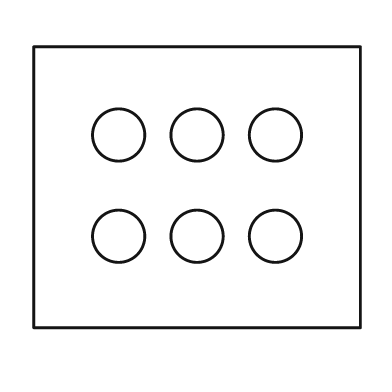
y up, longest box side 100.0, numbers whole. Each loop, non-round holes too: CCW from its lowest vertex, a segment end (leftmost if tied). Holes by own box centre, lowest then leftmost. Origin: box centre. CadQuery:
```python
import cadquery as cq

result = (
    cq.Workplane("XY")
    .moveTo(-50.0, -43.0)
    .lineTo(50.0, -43.0)
    .lineTo(50.0, 43.0)
    .lineTo(-50.0, 43.0)
    .close()
    .moveTo(-24.0, -15.0)
    .circle(8.0)
    .moveTo(0.0, -15.0)
    .circle(8.0)
    .moveTo(24.0, -15.0)
    .circle(8.0)
    .moveTo(-24.0, 16.0)
    .circle(8.0)
    .moveTo(0.0, 16.0)
    .circle(8.0)
    .moveTo(24.0, 16.0)
    .circle(8.0)
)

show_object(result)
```